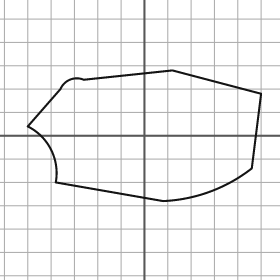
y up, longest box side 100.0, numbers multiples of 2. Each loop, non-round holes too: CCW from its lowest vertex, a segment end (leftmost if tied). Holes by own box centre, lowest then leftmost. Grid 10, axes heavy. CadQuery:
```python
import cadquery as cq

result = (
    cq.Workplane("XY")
    .moveTo(8.0, -28.0)
    .threePointArc((28.0, -24.0), (46.0, -14.0))
    .lineTo(50.0, 18.0)
    .lineTo(12.0, 28.0)
    .lineTo(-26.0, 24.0)
    .threePointArc((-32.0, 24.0), (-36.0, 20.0))
    .lineTo(-50.0, 4.0)
    .threePointArc((-40.0, -6.0), (-38.0, -20.0))
    .close()
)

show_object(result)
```